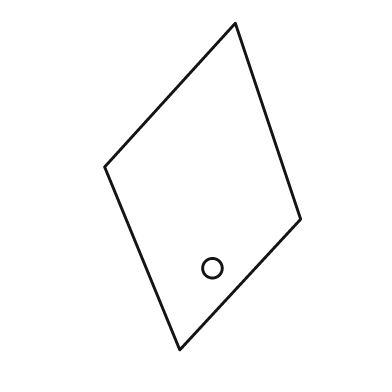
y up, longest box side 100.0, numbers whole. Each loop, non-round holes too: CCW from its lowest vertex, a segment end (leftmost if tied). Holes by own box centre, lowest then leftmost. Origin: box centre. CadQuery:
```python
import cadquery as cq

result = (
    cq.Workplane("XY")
    .moveTo(-7.0, -50.0)
    .lineTo(30.0, -10.0)
    .lineTo(10.0, 50.0)
    .lineTo(-30.0, 6.0)
    .close()
    .moveTo(3.0, -25.0)
    .circle(3.0)
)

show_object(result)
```